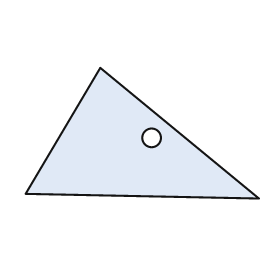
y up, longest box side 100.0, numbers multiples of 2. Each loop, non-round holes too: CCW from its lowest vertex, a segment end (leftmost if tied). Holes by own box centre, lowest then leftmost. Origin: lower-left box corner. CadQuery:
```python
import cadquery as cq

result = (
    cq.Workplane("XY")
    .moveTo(100.0, 0.0)
    .lineTo(32.0, 56.0)
    .lineTo(0.0, 2.0)
    .close()
    .moveTo(54.0, 26.0)
    .circle(4.0)
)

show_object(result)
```